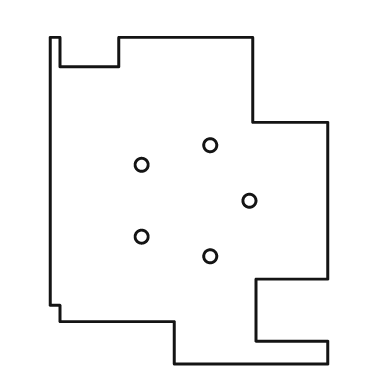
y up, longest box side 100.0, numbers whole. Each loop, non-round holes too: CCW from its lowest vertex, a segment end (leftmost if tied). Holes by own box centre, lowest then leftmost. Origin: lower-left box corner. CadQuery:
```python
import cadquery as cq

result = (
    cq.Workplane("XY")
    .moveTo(38.0, 0.0)
    .lineTo(85.0, 0.0)
    .lineTo(85.0, 7.0)
    .lineTo(63.0, 7.0)
    .lineTo(63.0, 26.0)
    .lineTo(85.0, 26.0)
    .lineTo(85.0, 74.0)
    .lineTo(62.0, 74.0)
    .lineTo(62.0, 100.0)
    .lineTo(21.0, 100.0)
    .lineTo(21.0, 91.0)
    .lineTo(3.0, 91.0)
    .lineTo(3.0, 100.0)
    .lineTo(0.0, 100.0)
    .lineTo(0.0, 18.0)
    .lineTo(3.0, 18.0)
    .lineTo(3.0, 13.0)
    .lineTo(38.0, 13.0)
    .close()
    .moveTo(49.0, 33.0)
    .circle(2.0)
    .moveTo(28.0, 39.0)
    .circle(2.0)
    .moveTo(61.0, 50.0)
    .circle(2.0)
    .moveTo(28.0, 61.0)
    .circle(2.0)
    .moveTo(49.0, 67.0)
    .circle(2.0)
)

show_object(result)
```